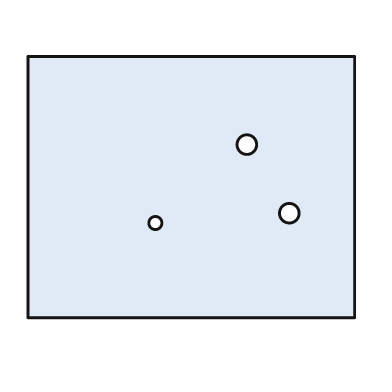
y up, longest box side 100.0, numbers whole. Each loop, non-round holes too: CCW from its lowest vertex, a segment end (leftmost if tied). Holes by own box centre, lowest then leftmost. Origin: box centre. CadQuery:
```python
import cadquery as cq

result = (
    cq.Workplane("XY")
    .moveTo(-50.0, -40.0)
    .lineTo(50.0, -40.0)
    .lineTo(50.0, 40.0)
    .lineTo(-50.0, 40.0)
    .close()
    .moveTo(-11.0, -11.0)
    .circle(2.0)
    .moveTo(30.0, -8.0)
    .circle(3.0)
    .moveTo(17.0, 13.0)
    .circle(3.0)
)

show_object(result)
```